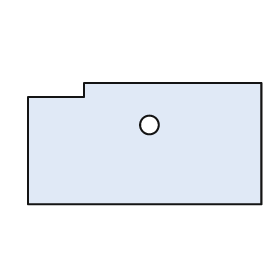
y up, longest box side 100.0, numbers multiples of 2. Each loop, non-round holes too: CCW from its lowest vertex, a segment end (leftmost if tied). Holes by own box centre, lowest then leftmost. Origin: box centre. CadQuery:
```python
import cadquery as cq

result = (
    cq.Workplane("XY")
    .moveTo(-50.0, -26.0)
    .lineTo(50.0, -26.0)
    .lineTo(50.0, 26.0)
    .lineTo(-26.0, 26.0)
    .lineTo(-26.0, 20.0)
    .lineTo(-50.0, 20.0)
    .close()
    .moveTo(2.0, 8.0)
    .circle(4.0)
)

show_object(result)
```